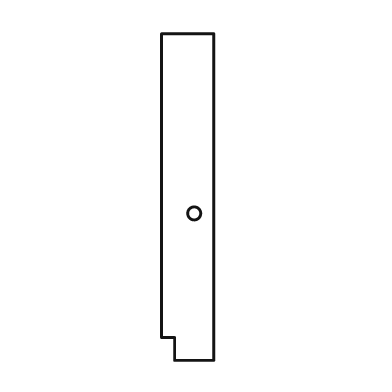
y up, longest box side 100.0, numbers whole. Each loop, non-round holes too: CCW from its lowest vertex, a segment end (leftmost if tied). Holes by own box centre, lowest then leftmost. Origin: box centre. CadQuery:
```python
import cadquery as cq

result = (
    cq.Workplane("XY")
    .moveTo(-4.0, -50.0)
    .lineTo(8.0, -50.0)
    .lineTo(8.0, 50.0)
    .lineTo(-8.0, 50.0)
    .lineTo(-8.0, -43.0)
    .lineTo(-4.0, -43.0)
    .close()
    .moveTo(2.0, -5.0)
    .circle(2.0)
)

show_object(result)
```